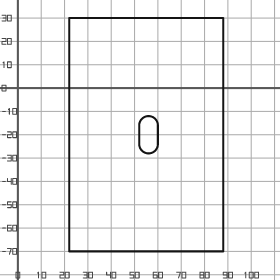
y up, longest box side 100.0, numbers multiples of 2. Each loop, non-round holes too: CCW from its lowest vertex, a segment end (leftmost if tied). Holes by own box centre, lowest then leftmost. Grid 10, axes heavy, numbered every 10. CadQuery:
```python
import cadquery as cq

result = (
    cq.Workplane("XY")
    .moveTo(22.0, -70.0)
    .lineTo(88.0, -70.0)
    .lineTo(88.0, 30.0)
    .lineTo(22.0, 30.0)
    .close()
    .moveTo(52.0, -24.0)
    .threePointArc((56.0, -28.0), (60.0, -24.0))
    .lineTo(60.0, -16.0)
    .threePointArc((56.0, -12.0), (52.0, -16.0))
    .close()
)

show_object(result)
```